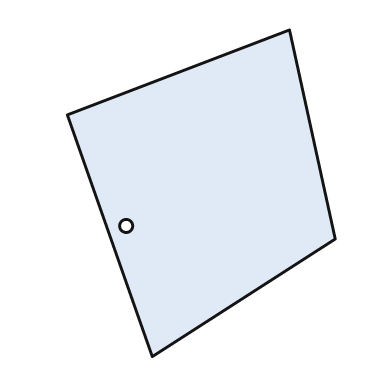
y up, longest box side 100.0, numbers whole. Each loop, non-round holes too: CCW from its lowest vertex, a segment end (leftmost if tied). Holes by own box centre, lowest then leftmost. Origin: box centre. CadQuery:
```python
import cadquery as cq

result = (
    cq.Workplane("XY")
    .moveTo(-15.0, -50.0)
    .lineTo(41.0, -14.0)
    .lineTo(27.0, 50.0)
    .lineTo(-41.0, 24.0)
    .close()
    .moveTo(-23.0, -10.0)
    .circle(2.0)
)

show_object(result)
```